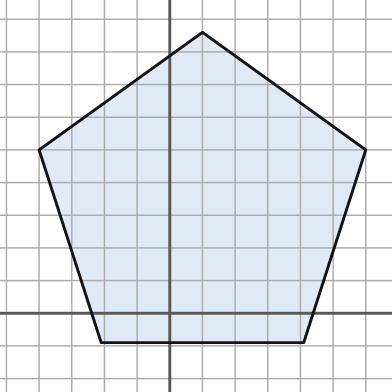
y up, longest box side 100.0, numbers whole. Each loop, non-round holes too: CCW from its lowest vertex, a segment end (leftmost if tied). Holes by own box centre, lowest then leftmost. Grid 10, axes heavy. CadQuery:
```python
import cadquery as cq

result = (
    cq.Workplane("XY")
    .moveTo(-21.0, -9.0)
    .lineTo(41.0, -9.0)
    .lineTo(60.0, 50.0)
    .lineTo(10.0, 86.0)
    .lineTo(-40.0, 50.0)
    .close()
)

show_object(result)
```